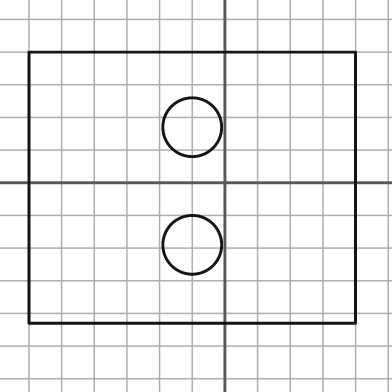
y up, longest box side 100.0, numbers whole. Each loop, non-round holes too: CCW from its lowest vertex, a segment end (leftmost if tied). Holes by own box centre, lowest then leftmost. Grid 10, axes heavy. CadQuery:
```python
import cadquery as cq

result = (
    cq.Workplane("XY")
    .moveTo(-60.0, -43.0)
    .lineTo(40.0, -43.0)
    .lineTo(40.0, 40.0)
    .lineTo(-60.0, 40.0)
    .close()
    .moveTo(-10.0, -19.0)
    .circle(9.0)
    .moveTo(-10.0, 17.0)
    .circle(9.0)
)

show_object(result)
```